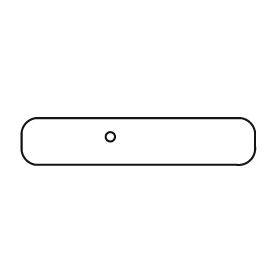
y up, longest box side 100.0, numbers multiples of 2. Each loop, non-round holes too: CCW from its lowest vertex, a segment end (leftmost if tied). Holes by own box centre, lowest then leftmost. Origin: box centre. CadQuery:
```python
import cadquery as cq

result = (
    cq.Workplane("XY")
    .moveTo(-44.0, -10.0)
    .lineTo(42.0, -10.0)
    .threePointArc((48.0, -8.0), (50.0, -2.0))
    .lineTo(50.0, 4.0)
    .threePointArc((48.0, 8.0), (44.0, 10.0))
    .lineTo(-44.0, 10.0)
    .threePointArc((-48.0, 8.0), (-50.0, 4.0))
    .lineTo(-50.0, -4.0)
    .threePointArc((-48.0, -8.0), (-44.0, -10.0))
    .close()
    .moveTo(-12.0, 2.0)
    .circle(2.0)
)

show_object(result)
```